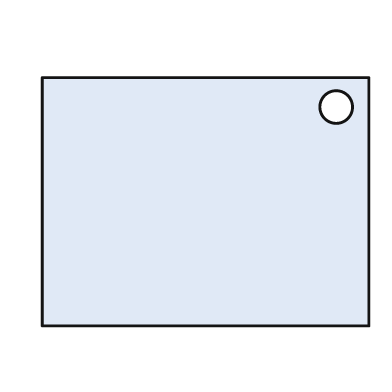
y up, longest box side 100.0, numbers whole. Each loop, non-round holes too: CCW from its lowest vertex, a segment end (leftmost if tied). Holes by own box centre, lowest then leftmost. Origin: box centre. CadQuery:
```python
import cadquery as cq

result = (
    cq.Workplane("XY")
    .moveTo(-50.0, -38.0)
    .lineTo(50.0, -38.0)
    .lineTo(50.0, 38.0)
    .lineTo(-50.0, 38.0)
    .close()
    .moveTo(40.0, 29.0)
    .circle(5.0)
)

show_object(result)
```